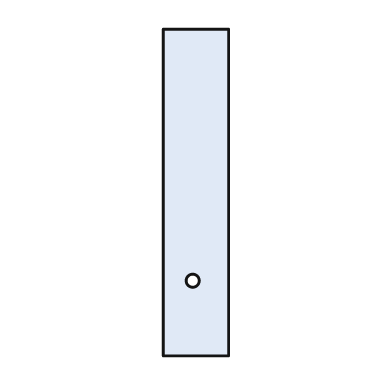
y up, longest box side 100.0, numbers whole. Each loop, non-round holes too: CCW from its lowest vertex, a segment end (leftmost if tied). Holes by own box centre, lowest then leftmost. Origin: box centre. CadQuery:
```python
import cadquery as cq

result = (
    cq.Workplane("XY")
    .moveTo(-10.0, -50.0)
    .lineTo(10.0, -50.0)
    .lineTo(10.0, 50.0)
    .lineTo(-10.0, 50.0)
    .close()
    .moveTo(-1.0, -27.0)
    .circle(2.0)
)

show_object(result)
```